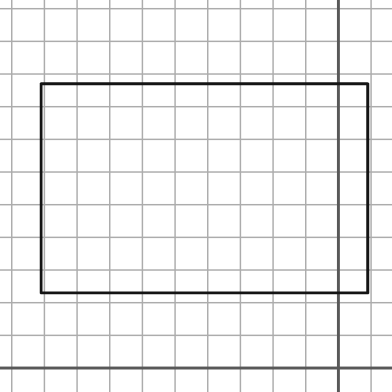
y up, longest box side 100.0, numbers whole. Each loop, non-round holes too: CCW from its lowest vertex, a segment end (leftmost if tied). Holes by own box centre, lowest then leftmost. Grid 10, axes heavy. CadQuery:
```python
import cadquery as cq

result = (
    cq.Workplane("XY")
    .moveTo(-91.0, 23.0)
    .lineTo(9.0, 23.0)
    .lineTo(9.0, 87.0)
    .lineTo(-91.0, 87.0)
    .close()
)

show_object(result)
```